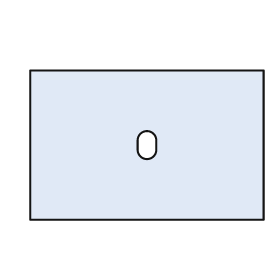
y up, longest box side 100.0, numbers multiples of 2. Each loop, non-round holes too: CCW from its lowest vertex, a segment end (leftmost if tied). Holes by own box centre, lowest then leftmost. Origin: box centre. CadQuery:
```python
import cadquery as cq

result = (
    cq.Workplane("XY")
    .moveTo(-50.0, -32.0)
    .lineTo(50.0, -32.0)
    .lineTo(50.0, 32.0)
    .lineTo(-50.0, 32.0)
    .close()
    .moveTo(-4.0, -2.0)
    .threePointArc((0.0, -6.0), (4.0, -2.0))
    .lineTo(4.0, 2.0)
    .threePointArc((0.0, 6.0), (-4.0, 2.0))
    .close()
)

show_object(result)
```